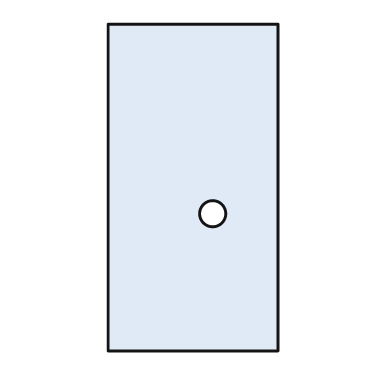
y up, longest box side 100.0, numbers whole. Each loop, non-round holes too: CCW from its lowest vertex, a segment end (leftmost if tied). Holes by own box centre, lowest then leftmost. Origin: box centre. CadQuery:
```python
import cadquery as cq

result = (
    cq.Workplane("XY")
    .moveTo(-26.0, -50.0)
    .lineTo(26.0, -50.0)
    .lineTo(26.0, 50.0)
    .lineTo(-26.0, 50.0)
    .close()
    .moveTo(6.0, -8.0)
    .circle(4.0)
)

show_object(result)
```